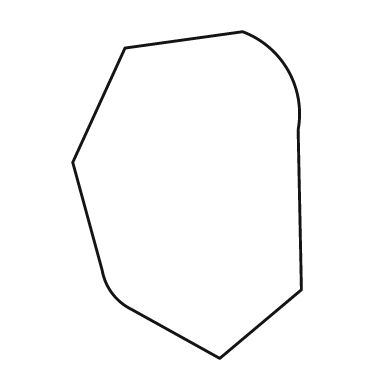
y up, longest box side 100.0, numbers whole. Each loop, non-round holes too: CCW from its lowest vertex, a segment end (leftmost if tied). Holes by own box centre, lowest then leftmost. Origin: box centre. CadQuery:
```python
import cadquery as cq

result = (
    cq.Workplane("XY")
    .moveTo(10.0, -50.0)
    .lineTo(35.0, -29.0)
    .lineTo(34.0, 20.0)
    .threePointArc((31.0, 38.0), (17.0, 50.0))
    .lineTo(-19.0, 45.0)
    .lineTo(-35.0, 10.0)
    .lineTo(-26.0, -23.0)
    .threePointArc((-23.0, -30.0), (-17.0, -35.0))
    .close()
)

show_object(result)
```